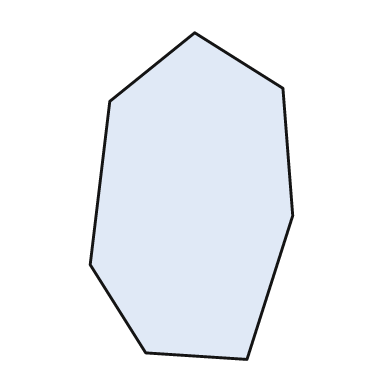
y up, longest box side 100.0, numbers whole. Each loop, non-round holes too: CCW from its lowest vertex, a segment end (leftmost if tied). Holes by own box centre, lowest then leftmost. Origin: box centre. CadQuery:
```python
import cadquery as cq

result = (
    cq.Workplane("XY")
    .moveTo(17.0, -50.0)
    .lineTo(31.0, -6.0)
    .lineTo(28.0, 33.0)
    .lineTo(1.0, 50.0)
    .lineTo(-25.0, 29.0)
    .lineTo(-31.0, -21.0)
    .lineTo(-14.0, -48.0)
    .close()
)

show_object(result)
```